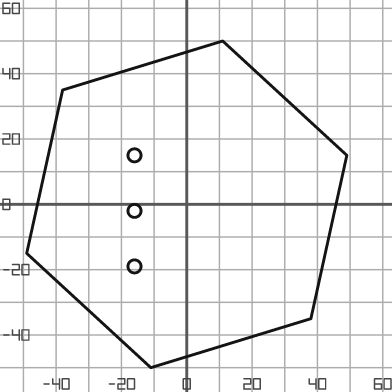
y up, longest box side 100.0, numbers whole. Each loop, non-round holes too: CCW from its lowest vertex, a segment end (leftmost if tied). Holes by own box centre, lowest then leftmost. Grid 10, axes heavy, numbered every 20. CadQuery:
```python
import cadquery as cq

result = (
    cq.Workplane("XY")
    .moveTo(-11.0, -50.0)
    .lineTo(38.0, -35.0)
    .lineTo(49.0, 15.0)
    .lineTo(11.0, 50.0)
    .lineTo(-38.0, 35.0)
    .lineTo(-49.0, -15.0)
    .close()
    .moveTo(-16.0, -19.0)
    .circle(2.0)
    .moveTo(-16.0, -2.0)
    .circle(2.0)
    .moveTo(-16.0, 15.0)
    .circle(2.0)
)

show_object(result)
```